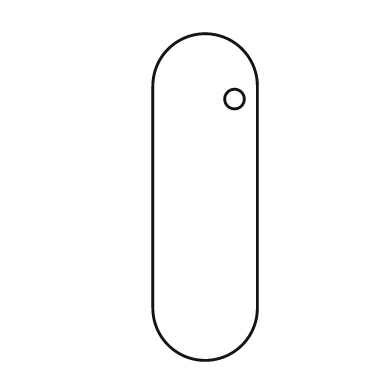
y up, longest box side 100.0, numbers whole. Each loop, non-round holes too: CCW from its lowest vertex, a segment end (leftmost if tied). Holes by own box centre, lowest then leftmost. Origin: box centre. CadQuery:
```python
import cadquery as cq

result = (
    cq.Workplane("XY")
    .moveTo(-16.0, -34.0)
    .threePointArc((0.0, -50.0), (16.0, -34.0))
    .lineTo(16.0, 34.0)
    .threePointArc((0.0, 50.0), (-16.0, 34.0))
    .close()
    .moveTo(9.0, 30.0)
    .circle(3.0)
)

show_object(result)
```